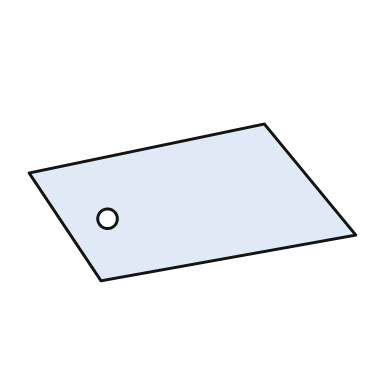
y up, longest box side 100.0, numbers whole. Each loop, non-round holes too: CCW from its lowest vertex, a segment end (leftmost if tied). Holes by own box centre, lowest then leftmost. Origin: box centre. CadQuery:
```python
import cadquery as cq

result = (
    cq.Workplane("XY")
    .moveTo(-28.0, -24.0)
    .lineTo(50.0, -10.0)
    .lineTo(22.0, 24.0)
    .lineTo(-50.0, 9.0)
    .close()
    .moveTo(-26.0, -5.0)
    .circle(3.0)
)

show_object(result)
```